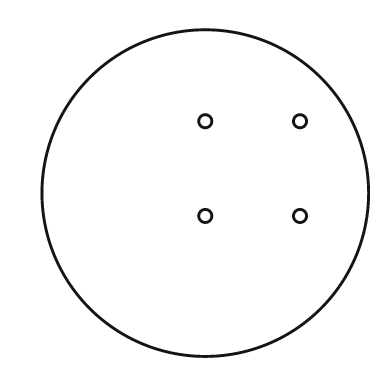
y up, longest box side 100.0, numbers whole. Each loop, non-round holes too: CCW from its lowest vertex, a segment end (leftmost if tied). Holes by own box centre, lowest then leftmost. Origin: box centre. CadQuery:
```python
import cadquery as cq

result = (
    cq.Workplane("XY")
    .moveTo(0.0, 0.0)
    .circle(50.0)
    .moveTo(0.0, -7.0)
    .circle(2.0)
    .moveTo(29.0, -7.0)
    .circle(2.0)
    .moveTo(0.0, 22.0)
    .circle(2.0)
    .moveTo(29.0, 22.0)
    .circle(2.0)
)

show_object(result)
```